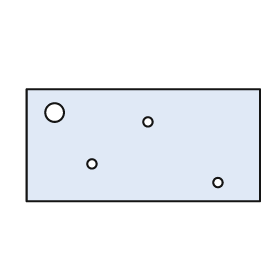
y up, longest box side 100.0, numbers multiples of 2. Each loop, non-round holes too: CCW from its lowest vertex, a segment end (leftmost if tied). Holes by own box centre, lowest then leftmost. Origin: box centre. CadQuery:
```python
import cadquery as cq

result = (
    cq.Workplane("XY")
    .moveTo(-50.0, -24.0)
    .lineTo(50.0, -24.0)
    .lineTo(50.0, 24.0)
    .lineTo(-50.0, 24.0)
    .close()
    .moveTo(32.0, -16.0)
    .circle(2.0)
    .moveTo(-22.0, -8.0)
    .circle(2.0)
    .moveTo(2.0, 10.0)
    .circle(2.0)
    .moveTo(-38.0, 14.0)
    .circle(4.0)
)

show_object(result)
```